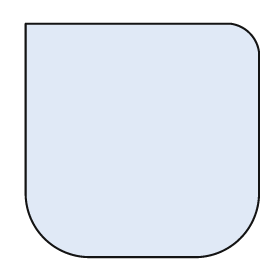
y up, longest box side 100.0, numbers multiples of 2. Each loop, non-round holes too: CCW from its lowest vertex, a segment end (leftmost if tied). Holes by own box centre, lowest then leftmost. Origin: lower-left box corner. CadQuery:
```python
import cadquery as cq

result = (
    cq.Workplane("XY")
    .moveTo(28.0, 0.0)
    .lineTo(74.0, 0.0)
    .threePointArc((92.0, 8.0), (100.0, 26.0))
    .lineTo(100.0, 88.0)
    .threePointArc((96.0, 96.0), (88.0, 100.0))
    .lineTo(0.0, 100.0)
    .lineTo(0.0, 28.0)
    .threePointArc((8.0, 8.0), (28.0, 0.0))
    .close()
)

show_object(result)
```